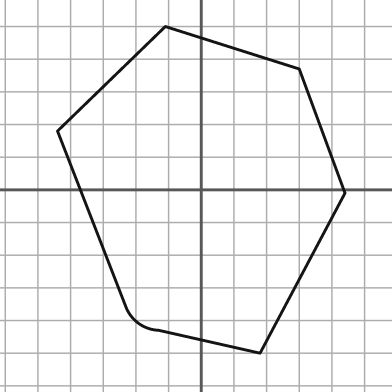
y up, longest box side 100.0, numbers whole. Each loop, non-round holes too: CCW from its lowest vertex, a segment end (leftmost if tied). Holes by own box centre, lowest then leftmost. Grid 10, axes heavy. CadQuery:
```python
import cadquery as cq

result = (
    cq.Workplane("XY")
    .moveTo(18.0, -50.0)
    .lineTo(44.0, -1.0)
    .lineTo(30.0, 37.0)
    .lineTo(-11.0, 50.0)
    .lineTo(-44.0, 18.0)
    .lineTo(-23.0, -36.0)
    .threePointArc((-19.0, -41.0), (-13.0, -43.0))
    .close()
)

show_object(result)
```